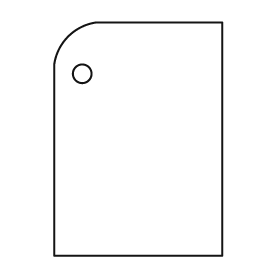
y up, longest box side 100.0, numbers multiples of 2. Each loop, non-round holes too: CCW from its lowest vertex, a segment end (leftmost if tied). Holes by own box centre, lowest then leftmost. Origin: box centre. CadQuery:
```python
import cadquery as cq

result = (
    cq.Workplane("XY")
    .moveTo(-36.0, -50.0)
    .lineTo(36.0, -50.0)
    .lineTo(36.0, 50.0)
    .lineTo(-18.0, 50.0)
    .threePointArc((-30.0, 44.0), (-36.0, 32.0))
    .close()
    .moveTo(-24.0, 28.0)
    .circle(4.0)
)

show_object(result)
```